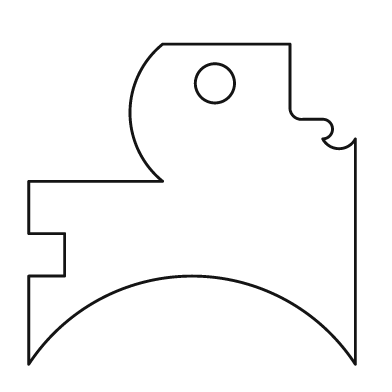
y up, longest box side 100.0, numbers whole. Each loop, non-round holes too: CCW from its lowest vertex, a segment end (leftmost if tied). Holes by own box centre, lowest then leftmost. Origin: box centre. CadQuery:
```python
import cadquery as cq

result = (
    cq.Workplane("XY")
    .moveTo(-50.0, -49.0)
    .threePointArc((0.0, -22.0), (50.0, -49.0))
    .lineTo(50.0, 20.0)
    .threePointArc((45.0, 17.0), (40.0, 20.0))
    .threePointArc((43.0, 23.0), (40.0, 26.0))
    .lineTo(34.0, 26.0)
    .threePointArc((31.0, 27.0), (30.0, 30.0))
    .lineTo(30.0, 49.0)
    .lineTo(-9.0, 49.0)
    .threePointArc((-19.0, 28.0), (-9.0, 7.0))
    .lineTo(-50.0, 7.0)
    .lineTo(-50.0, -9.0)
    .lineTo(-39.0, -9.0)
    .lineTo(-39.0, -22.0)
    .lineTo(-50.0, -22.0)
    .close()
    .moveTo(7.0, 37.0)
    .circle(6.0)
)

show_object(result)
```